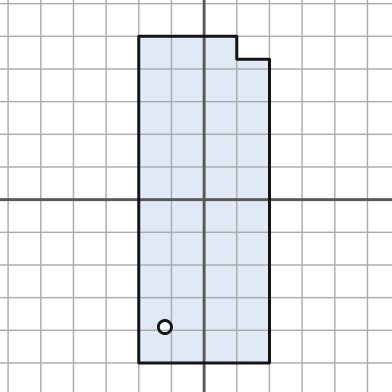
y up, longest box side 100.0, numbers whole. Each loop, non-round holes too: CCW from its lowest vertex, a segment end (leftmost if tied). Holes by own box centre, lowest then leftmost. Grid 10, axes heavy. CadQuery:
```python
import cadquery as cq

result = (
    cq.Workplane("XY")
    .moveTo(-20.0, -50.0)
    .lineTo(20.0, -50.0)
    .lineTo(20.0, 43.0)
    .lineTo(10.0, 43.0)
    .lineTo(10.0, 50.0)
    .lineTo(-20.0, 50.0)
    .close()
    .moveTo(-12.0, -39.0)
    .circle(2.0)
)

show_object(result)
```